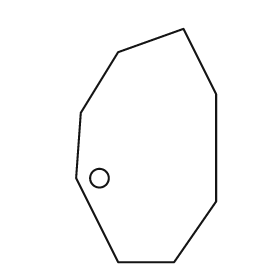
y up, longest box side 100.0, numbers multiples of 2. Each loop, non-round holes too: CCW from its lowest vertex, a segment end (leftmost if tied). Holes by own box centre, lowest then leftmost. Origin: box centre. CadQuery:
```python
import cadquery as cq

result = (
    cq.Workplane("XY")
    .moveTo(-12.0, -50.0)
    .lineTo(12.0, -50.0)
    .lineTo(30.0, -24.0)
    .lineTo(30.0, 22.0)
    .lineTo(16.0, 50.0)
    .lineTo(-12.0, 40.0)
    .lineTo(-28.0, 14.0)
    .lineTo(-30.0, -14.0)
    .close()
    .moveTo(-20.0, -14.0)
    .circle(4.0)
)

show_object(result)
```